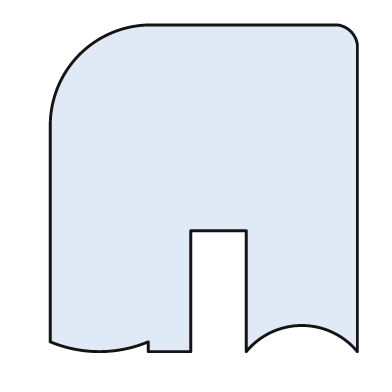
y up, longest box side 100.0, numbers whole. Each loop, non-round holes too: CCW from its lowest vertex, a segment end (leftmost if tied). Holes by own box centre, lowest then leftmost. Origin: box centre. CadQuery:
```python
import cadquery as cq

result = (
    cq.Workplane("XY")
    .moveTo(-17.0, -50.0)
    .lineTo(-4.0, -50.0)
    .lineTo(-4.0, -13.0)
    .lineTo(13.0, -13.0)
    .lineTo(13.0, -50.0)
    .threePointArc((30.0, -42.0), (47.0, -50.0))
    .lineTo(47.0, 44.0)
    .threePointArc((45.0, 48.0), (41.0, 50.0))
    .lineTo(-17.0, 50.0)
    .threePointArc((-38.0, 41.0), (-47.0, 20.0))
    .lineTo(-47.0, -47.0)
    .threePointArc((-32.0, -50.0), (-17.0, -47.0))
    .close()
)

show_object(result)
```